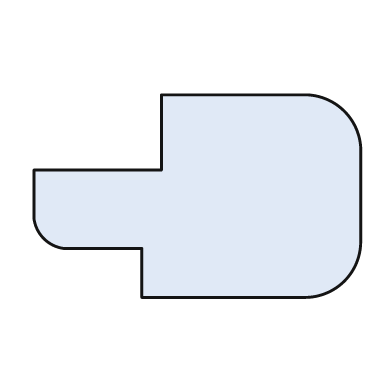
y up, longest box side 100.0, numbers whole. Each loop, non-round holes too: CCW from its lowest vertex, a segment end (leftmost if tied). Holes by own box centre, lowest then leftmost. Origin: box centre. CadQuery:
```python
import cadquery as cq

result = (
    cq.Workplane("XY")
    .moveTo(-17.0, -31.0)
    .lineTo(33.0, -31.0)
    .threePointArc((45.0, -26.0), (50.0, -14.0))
    .lineTo(50.0, 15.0)
    .threePointArc((45.0, 26.0), (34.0, 31.0))
    .lineTo(-11.0, 31.0)
    .lineTo(-11.0, 8.0)
    .lineTo(-50.0, 8.0)
    .lineTo(-50.0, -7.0)
    .threePointArc((-47.0, -13.0), (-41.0, -16.0))
    .lineTo(-17.0, -16.0)
    .close()
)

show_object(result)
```